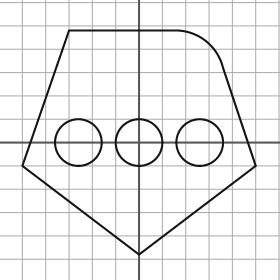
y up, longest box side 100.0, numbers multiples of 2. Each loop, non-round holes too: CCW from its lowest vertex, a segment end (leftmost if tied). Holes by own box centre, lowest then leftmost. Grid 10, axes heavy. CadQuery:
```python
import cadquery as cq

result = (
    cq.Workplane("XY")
    .moveTo(0.0, -48.0)
    .lineTo(50.0, -10.0)
    .lineTo(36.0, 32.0)
    .threePointArc((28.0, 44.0), (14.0, 48.0))
    .lineTo(-30.0, 48.0)
    .lineTo(-50.0, -10.0)
    .close()
    .moveTo(-26.0, 0.0)
    .circle(10.0)
    .moveTo(0.0, 0.0)
    .circle(10.0)
    .moveTo(26.0, 0.0)
    .circle(10.0)
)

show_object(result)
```